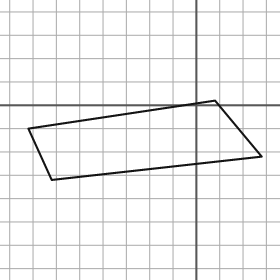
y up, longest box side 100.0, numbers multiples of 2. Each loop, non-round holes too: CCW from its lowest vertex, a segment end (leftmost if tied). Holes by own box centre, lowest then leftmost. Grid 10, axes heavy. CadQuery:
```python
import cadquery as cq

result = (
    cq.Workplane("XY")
    .moveTo(-62.0, -32.0)
    .lineTo(28.0, -22.0)
    .lineTo(8.0, 2.0)
    .lineTo(-72.0, -10.0)
    .close()
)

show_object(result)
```